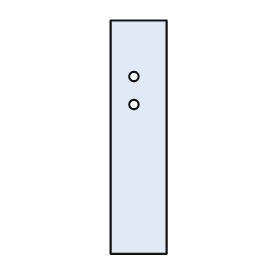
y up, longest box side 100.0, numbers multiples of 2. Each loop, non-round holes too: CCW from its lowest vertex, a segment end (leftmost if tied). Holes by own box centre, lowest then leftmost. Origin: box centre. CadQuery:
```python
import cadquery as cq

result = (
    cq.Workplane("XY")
    .moveTo(-12.0, -50.0)
    .lineTo(12.0, -50.0)
    .lineTo(12.0, 50.0)
    .lineTo(-12.0, 50.0)
    .close()
    .moveTo(-2.0, 14.0)
    .circle(2.0)
    .moveTo(-2.0, 26.0)
    .circle(2.0)
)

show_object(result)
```